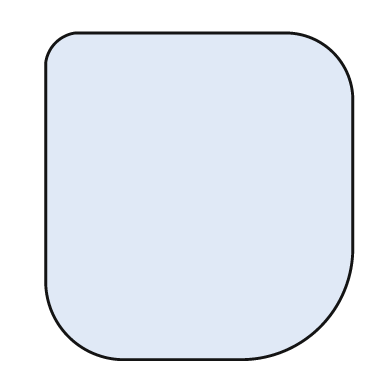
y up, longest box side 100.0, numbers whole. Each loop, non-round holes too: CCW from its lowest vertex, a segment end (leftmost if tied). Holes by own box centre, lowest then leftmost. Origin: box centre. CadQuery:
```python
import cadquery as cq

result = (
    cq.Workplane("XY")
    .moveTo(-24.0, -50.0)
    .lineTo(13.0, -50.0)
    .threePointArc((37.0, -40.0), (47.0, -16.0))
    .lineTo(47.0, 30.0)
    .threePointArc((41.0, 44.0), (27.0, 50.0))
    .lineTo(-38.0, 50.0)
    .threePointArc((-44.0, 47.0), (-47.0, 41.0))
    .lineTo(-47.0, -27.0)
    .threePointArc((-40.0, -43.0), (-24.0, -50.0))
    .close()
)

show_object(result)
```